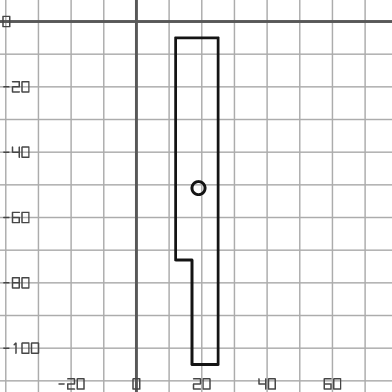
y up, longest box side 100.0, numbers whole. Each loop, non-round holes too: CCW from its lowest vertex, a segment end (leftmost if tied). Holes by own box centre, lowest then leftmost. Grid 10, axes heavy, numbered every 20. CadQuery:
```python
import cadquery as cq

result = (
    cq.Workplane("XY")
    .moveTo(17.0, -105.0)
    .lineTo(25.0, -105.0)
    .lineTo(25.0, -5.0)
    .lineTo(12.0, -5.0)
    .lineTo(12.0, -73.0)
    .lineTo(17.0, -73.0)
    .close()
    .moveTo(19.0, -51.0)
    .circle(2.0)
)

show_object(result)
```